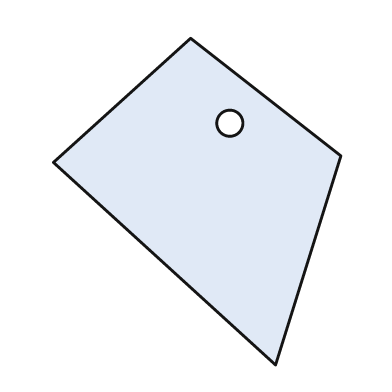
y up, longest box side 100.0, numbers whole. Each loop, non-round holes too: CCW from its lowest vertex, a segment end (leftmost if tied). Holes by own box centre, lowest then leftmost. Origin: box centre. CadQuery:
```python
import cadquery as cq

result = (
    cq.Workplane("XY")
    .moveTo(24.0, -50.0)
    .lineTo(44.0, 14.0)
    .lineTo(-2.0, 50.0)
    .lineTo(-44.0, 12.0)
    .close()
    .moveTo(10.0, 24.0)
    .circle(4.0)
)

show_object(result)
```